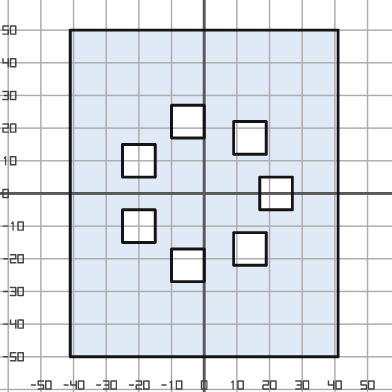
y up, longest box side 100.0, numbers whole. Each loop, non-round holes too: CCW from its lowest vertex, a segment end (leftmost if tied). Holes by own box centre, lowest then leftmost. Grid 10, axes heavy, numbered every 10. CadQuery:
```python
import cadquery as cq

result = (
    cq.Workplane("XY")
    .moveTo(-41.0, -50.0)
    .lineTo(41.0, -50.0)
    .lineTo(41.0, 50.0)
    .lineTo(-41.0, 50.0)
    .close()
    .moveTo(-10.0, -27.0)
    .lineTo(0.0, -27.0)
    .lineTo(0.0, -17.0)
    .lineTo(-10.0, -17.0)
    .close()
    .moveTo(9.0, -22.0)
    .lineTo(19.0, -22.0)
    .lineTo(19.0, -12.0)
    .lineTo(9.0, -12.0)
    .close()
    .moveTo(-25.0, -15.0)
    .lineTo(-15.0, -15.0)
    .lineTo(-15.0, -5.0)
    .lineTo(-25.0, -5.0)
    .close()
    .moveTo(17.0, -5.0)
    .lineTo(27.0, -5.0)
    .lineTo(27.0, 5.0)
    .lineTo(17.0, 5.0)
    .close()
    .moveTo(-25.0, 5.0)
    .lineTo(-15.0, 5.0)
    .lineTo(-15.0, 15.0)
    .lineTo(-25.0, 15.0)
    .close()
    .moveTo(9.0, 12.0)
    .lineTo(19.0, 12.0)
    .lineTo(19.0, 22.0)
    .lineTo(9.0, 22.0)
    .close()
    .moveTo(-10.0, 17.0)
    .lineTo(0.0, 17.0)
    .lineTo(0.0, 27.0)
    .lineTo(-10.0, 27.0)
    .close()
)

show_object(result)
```